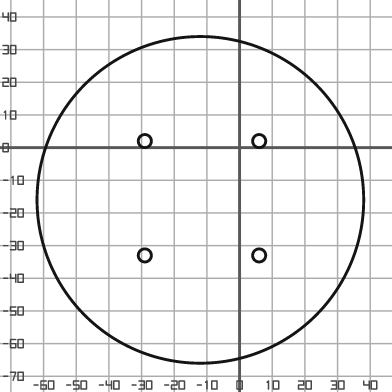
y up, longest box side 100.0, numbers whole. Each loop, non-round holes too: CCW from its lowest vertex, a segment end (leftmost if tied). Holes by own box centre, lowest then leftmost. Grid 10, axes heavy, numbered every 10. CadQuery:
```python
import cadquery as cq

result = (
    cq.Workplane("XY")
    .moveTo(-12.0, -16.0)
    .circle(50.0)
    .moveTo(-29.0, -33.0)
    .circle(2.0)
    .moveTo(6.0, -33.0)
    .circle(2.0)
    .moveTo(-29.0, 2.0)
    .circle(2.0)
    .moveTo(6.0, 2.0)
    .circle(2.0)
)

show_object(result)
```